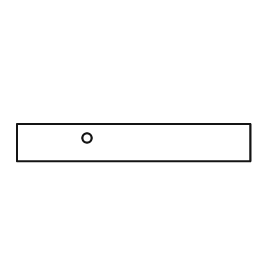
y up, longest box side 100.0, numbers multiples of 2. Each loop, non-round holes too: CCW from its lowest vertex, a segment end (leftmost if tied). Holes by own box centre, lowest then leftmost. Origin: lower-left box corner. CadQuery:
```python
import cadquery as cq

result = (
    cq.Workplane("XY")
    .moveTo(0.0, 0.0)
    .lineTo(100.0, 0.0)
    .lineTo(100.0, 16.0)
    .lineTo(0.0, 16.0)
    .close()
    .moveTo(30.0, 10.0)
    .circle(2.0)
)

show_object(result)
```